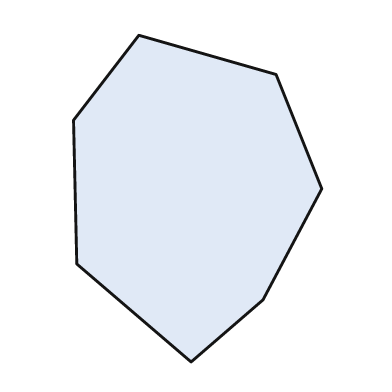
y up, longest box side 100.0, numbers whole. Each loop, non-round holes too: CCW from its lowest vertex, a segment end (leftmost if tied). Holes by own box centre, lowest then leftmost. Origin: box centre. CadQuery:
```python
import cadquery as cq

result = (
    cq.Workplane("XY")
    .moveTo(-2.0, -50.0)
    .lineTo(20.0, -31.0)
    .lineTo(38.0, 3.0)
    .lineTo(24.0, 38.0)
    .lineTo(-18.0, 50.0)
    .lineTo(-38.0, 24.0)
    .lineTo(-37.0, -20.0)
    .close()
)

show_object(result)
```